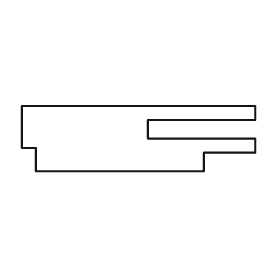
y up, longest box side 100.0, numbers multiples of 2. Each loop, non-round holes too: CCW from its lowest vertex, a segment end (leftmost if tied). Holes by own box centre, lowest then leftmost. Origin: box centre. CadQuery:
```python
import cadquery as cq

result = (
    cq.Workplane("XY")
    .moveTo(-44.0, -14.0)
    .lineTo(28.0, -14.0)
    .lineTo(28.0, -6.0)
    .lineTo(50.0, -6.0)
    .lineTo(50.0, 0.0)
    .lineTo(4.0, 0.0)
    .lineTo(4.0, 8.0)
    .lineTo(50.0, 8.0)
    .lineTo(50.0, 14.0)
    .lineTo(-50.0, 14.0)
    .lineTo(-50.0, -4.0)
    .lineTo(-44.0, -4.0)
    .close()
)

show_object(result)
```